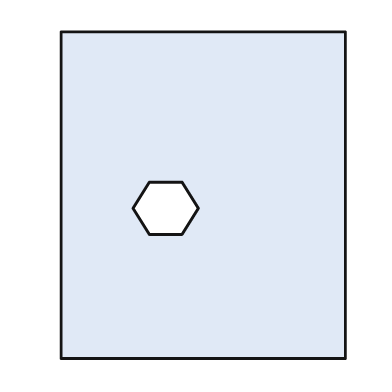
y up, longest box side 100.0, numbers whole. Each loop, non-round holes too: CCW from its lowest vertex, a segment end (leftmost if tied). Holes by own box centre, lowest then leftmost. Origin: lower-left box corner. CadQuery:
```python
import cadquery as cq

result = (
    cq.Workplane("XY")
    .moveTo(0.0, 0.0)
    .lineTo(87.0, 0.0)
    .lineTo(87.0, 100.0)
    .lineTo(0.0, 100.0)
    .close()
    .moveTo(27.0, 38.0)
    .lineTo(37.0, 38.0)
    .lineTo(42.0, 46.0)
    .lineTo(37.0, 54.0)
    .lineTo(27.0, 54.0)
    .lineTo(22.0, 46.0)
    .close()
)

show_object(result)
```